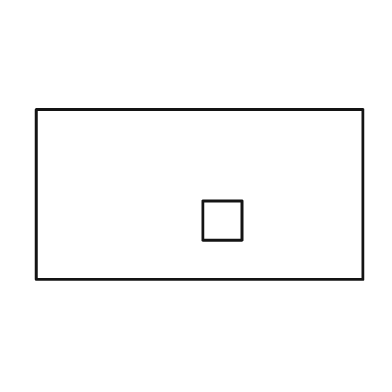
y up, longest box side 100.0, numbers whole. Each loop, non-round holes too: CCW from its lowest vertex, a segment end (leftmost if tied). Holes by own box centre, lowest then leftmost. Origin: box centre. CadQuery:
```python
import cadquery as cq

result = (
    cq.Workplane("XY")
    .moveTo(-50.0, -26.0)
    .lineTo(50.0, -26.0)
    .lineTo(50.0, 26.0)
    .lineTo(-50.0, 26.0)
    .close()
    .moveTo(1.0, -14.0)
    .lineTo(13.0, -14.0)
    .lineTo(13.0, -2.0)
    .lineTo(1.0, -2.0)
    .close()
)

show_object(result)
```